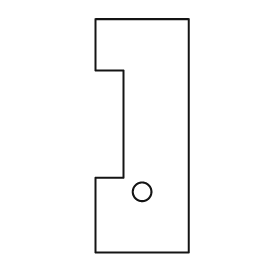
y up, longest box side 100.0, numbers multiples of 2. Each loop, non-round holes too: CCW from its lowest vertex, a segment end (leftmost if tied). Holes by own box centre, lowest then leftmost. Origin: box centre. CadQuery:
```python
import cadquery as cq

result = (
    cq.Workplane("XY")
    .moveTo(-20.0, -50.0)
    .lineTo(20.0, -50.0)
    .lineTo(20.0, 50.0)
    .lineTo(-20.0, 50.0)
    .lineTo(-20.0, 28.0)
    .lineTo(-8.0, 28.0)
    .lineTo(-8.0, -18.0)
    .lineTo(-20.0, -18.0)
    .close()
    .moveTo(0.0, -24.0)
    .circle(4.0)
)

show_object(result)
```